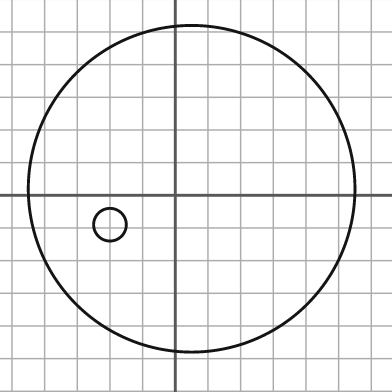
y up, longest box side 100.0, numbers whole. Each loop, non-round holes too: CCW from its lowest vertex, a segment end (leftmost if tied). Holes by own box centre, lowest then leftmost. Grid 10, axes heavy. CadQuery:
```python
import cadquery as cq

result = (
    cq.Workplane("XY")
    .moveTo(5.0, 2.0)
    .circle(50.0)
    .moveTo(-20.0, -9.0)
    .circle(5.0)
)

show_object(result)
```